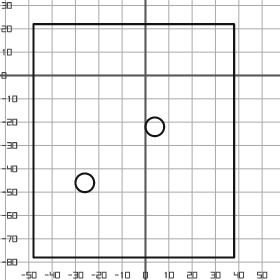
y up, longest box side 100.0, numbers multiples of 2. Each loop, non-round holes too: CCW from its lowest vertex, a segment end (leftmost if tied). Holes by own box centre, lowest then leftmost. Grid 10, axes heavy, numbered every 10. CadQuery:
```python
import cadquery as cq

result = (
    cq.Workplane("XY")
    .moveTo(-48.0, -78.0)
    .lineTo(38.0, -78.0)
    .lineTo(38.0, 22.0)
    .lineTo(-48.0, 22.0)
    .close()
    .moveTo(-26.0, -46.0)
    .circle(4.0)
    .moveTo(4.0, -22.0)
    .circle(4.0)
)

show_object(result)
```